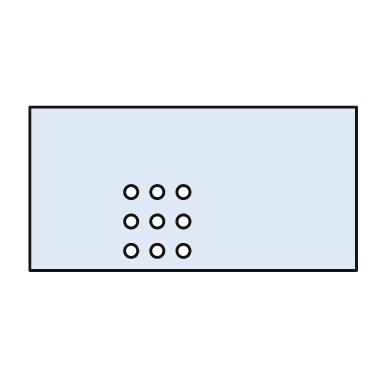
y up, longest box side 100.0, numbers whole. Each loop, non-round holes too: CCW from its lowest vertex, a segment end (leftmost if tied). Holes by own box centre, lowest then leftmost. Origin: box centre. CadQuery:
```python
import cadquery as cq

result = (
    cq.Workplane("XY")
    .moveTo(-50.0, -25.0)
    .lineTo(50.0, -25.0)
    .lineTo(50.0, 25.0)
    .lineTo(-50.0, 25.0)
    .close()
    .moveTo(-19.0, -19.0)
    .circle(2.0)
    .moveTo(-11.0, -19.0)
    .circle(2.0)
    .moveTo(-3.0, -19.0)
    .circle(2.0)
    .moveTo(-19.0, -10.0)
    .circle(2.0)
    .moveTo(-11.0, -10.0)
    .circle(2.0)
    .moveTo(-3.0, -10.0)
    .circle(2.0)
    .moveTo(-19.0, -1.0)
    .circle(2.0)
    .moveTo(-11.0, -1.0)
    .circle(2.0)
    .moveTo(-3.0, -1.0)
    .circle(2.0)
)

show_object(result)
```